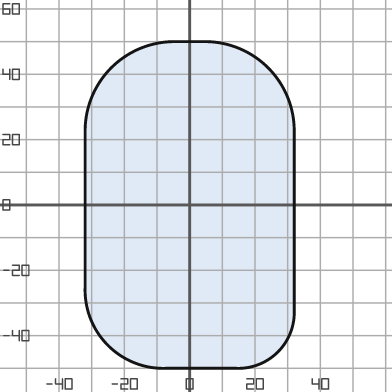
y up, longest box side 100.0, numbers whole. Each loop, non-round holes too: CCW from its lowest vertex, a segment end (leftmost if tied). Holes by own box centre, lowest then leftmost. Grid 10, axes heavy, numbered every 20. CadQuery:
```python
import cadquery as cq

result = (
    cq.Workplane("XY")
    .moveTo(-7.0, -50.0)
    .lineTo(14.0, -50.0)
    .threePointArc((27.0, -45.0), (32.0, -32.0))
    .lineTo(32.0, 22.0)
    .threePointArc((24.0, 42.0), (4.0, 50.0))
    .lineTo(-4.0, 50.0)
    .threePointArc((-24.0, 42.0), (-32.0, 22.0))
    .lineTo(-32.0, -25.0)
    .threePointArc((-25.0, -43.0), (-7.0, -50.0))
    .close()
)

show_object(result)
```